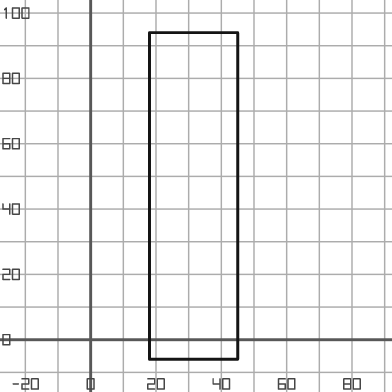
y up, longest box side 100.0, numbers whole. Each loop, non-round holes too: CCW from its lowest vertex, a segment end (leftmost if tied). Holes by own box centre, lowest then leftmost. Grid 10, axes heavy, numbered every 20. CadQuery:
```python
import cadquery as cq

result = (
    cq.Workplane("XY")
    .moveTo(18.0, -6.0)
    .lineTo(45.0, -6.0)
    .lineTo(45.0, 94.0)
    .lineTo(18.0, 94.0)
    .close()
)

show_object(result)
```